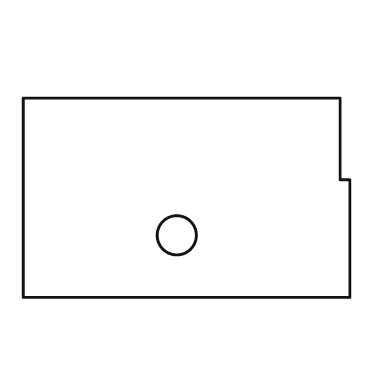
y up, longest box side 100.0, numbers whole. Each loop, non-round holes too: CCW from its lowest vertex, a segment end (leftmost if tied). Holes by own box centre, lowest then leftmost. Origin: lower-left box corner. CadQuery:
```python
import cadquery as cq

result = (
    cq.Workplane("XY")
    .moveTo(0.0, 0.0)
    .lineTo(100.0, 0.0)
    .lineTo(100.0, 36.0)
    .lineTo(97.0, 36.0)
    .lineTo(97.0, 61.0)
    .lineTo(0.0, 61.0)
    .close()
    .moveTo(47.0, 19.0)
    .circle(6.0)
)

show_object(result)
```